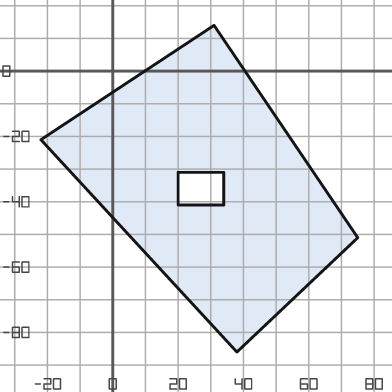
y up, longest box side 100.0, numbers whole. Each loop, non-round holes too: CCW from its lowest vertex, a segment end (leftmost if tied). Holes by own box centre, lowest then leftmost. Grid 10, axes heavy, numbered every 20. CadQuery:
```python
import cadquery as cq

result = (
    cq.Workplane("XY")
    .moveTo(38.0, -86.0)
    .lineTo(75.0, -51.0)
    .lineTo(31.0, 14.0)
    .lineTo(-22.0, -21.0)
    .close()
    .moveTo(20.0, -41.0)
    .lineTo(34.0, -41.0)
    .lineTo(34.0, -31.0)
    .lineTo(20.0, -31.0)
    .close()
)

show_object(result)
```